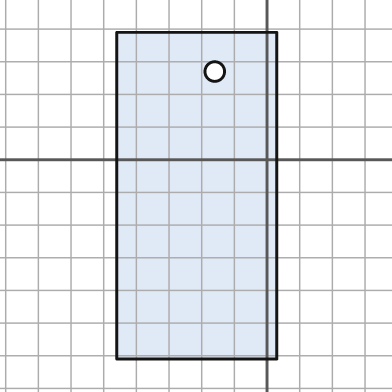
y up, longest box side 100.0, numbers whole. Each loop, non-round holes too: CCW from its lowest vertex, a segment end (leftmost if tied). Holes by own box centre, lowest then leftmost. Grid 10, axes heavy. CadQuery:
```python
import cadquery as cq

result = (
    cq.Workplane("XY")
    .moveTo(-46.0, -61.0)
    .lineTo(3.0, -61.0)
    .lineTo(3.0, 39.0)
    .lineTo(-46.0, 39.0)
    .close()
    .moveTo(-16.0, 27.0)
    .circle(3.0)
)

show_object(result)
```